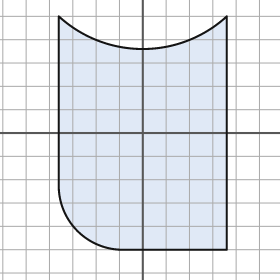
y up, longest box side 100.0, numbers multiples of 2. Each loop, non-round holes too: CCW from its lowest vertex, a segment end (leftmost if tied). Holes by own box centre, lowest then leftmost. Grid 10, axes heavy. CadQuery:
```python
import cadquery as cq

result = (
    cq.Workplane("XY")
    .moveTo(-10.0, -50.0)
    .lineTo(36.0, -50.0)
    .lineTo(36.0, 50.0)
    .threePointArc((0.0, 36.0), (-36.0, 50.0))
    .lineTo(-36.0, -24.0)
    .threePointArc((-28.0, -42.0), (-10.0, -50.0))
    .close()
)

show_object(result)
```